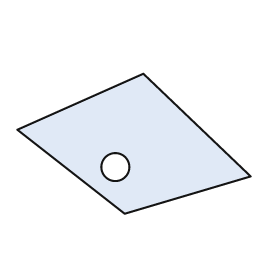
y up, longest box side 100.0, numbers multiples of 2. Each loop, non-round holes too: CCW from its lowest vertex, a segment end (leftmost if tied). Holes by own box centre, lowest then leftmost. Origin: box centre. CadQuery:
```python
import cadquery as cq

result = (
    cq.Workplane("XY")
    .moveTo(-4.0, -30.0)
    .lineTo(50.0, -14.0)
    .lineTo(4.0, 30.0)
    .lineTo(-50.0, 6.0)
    .close()
    .moveTo(-8.0, -10.0)
    .circle(6.0)
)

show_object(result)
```